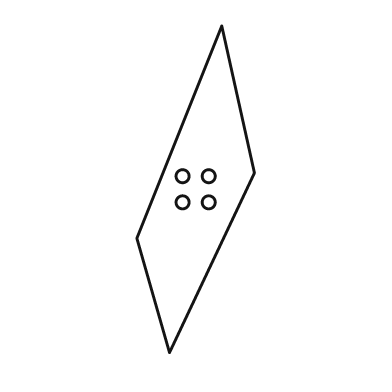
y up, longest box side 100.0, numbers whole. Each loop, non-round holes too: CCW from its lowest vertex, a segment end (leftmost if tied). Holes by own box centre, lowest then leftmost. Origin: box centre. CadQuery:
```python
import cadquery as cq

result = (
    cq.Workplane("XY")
    .moveTo(-8.0, -50.0)
    .lineTo(18.0, 5.0)
    .lineTo(8.0, 50.0)
    .lineTo(-18.0, -15.0)
    .close()
    .moveTo(-4.0, -4.0)
    .circle(2.0)
    .moveTo(4.0, -4.0)
    .circle(2.0)
    .moveTo(-4.0, 4.0)
    .circle(2.0)
    .moveTo(4.0, 4.0)
    .circle(2.0)
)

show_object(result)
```